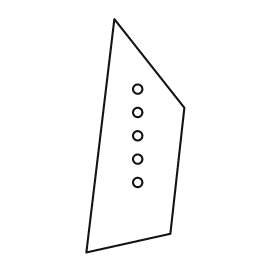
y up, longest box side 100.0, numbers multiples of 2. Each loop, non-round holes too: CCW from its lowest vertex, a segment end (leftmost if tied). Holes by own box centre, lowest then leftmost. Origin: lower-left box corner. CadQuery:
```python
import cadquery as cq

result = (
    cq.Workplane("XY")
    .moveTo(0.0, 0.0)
    .lineTo(36.0, 8.0)
    .lineTo(42.0, 62.0)
    .lineTo(12.0, 100.0)
    .close()
    .moveTo(22.0, 30.0)
    .circle(2.0)
    .moveTo(22.0, 40.0)
    .circle(2.0)
    .moveTo(22.0, 50.0)
    .circle(2.0)
    .moveTo(22.0, 60.0)
    .circle(2.0)
    .moveTo(22.0, 70.0)
    .circle(2.0)
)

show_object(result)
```